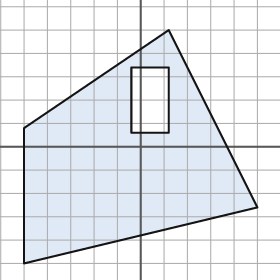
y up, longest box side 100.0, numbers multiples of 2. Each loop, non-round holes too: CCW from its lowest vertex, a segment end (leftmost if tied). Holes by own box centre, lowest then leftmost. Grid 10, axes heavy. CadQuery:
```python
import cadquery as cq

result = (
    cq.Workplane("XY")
    .moveTo(-50.0, -50.0)
    .lineTo(50.0, -26.0)
    .lineTo(12.0, 50.0)
    .lineTo(-50.0, 8.0)
    .close()
    .moveTo(-4.0, 6.0)
    .lineTo(12.0, 6.0)
    .lineTo(12.0, 34.0)
    .lineTo(-4.0, 34.0)
    .close()
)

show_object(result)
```